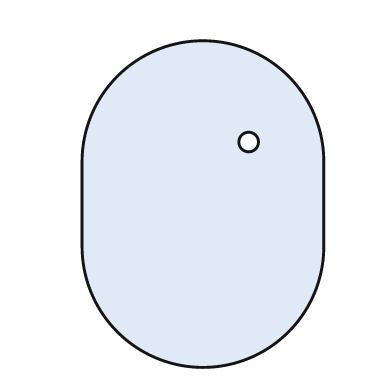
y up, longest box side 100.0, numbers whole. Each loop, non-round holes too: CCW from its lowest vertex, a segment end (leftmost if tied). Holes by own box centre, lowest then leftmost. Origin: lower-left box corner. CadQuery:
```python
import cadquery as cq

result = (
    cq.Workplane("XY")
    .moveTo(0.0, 37.0)
    .threePointArc((37.0, 0.0), (74.0, 37.0))
    .lineTo(74.0, 63.0)
    .threePointArc((37.0, 100.0), (0.0, 63.0))
    .close()
    .moveTo(51.0, 69.0)
    .circle(3.0)
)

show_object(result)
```